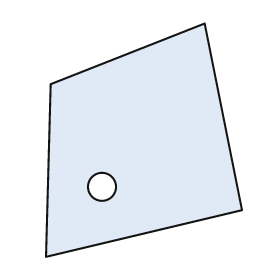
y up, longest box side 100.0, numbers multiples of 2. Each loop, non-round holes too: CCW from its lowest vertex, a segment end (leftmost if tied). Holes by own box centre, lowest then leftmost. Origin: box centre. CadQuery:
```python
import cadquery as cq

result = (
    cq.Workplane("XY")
    .moveTo(-42.0, -50.0)
    .lineTo(42.0, -30.0)
    .lineTo(26.0, 50.0)
    .lineTo(-40.0, 24.0)
    .close()
    .moveTo(-18.0, -20.0)
    .circle(6.0)
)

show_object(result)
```